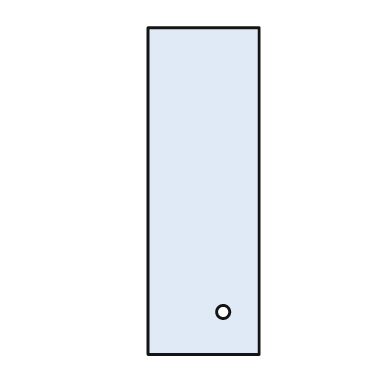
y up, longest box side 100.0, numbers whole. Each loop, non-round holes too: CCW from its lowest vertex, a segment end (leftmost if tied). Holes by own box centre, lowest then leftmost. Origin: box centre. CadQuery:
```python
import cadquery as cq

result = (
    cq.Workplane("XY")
    .moveTo(-17.0, -50.0)
    .lineTo(17.0, -50.0)
    .lineTo(17.0, 50.0)
    .lineTo(-17.0, 50.0)
    .close()
    .moveTo(6.0, -37.0)
    .circle(2.0)
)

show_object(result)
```